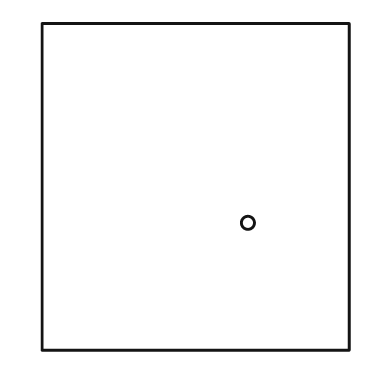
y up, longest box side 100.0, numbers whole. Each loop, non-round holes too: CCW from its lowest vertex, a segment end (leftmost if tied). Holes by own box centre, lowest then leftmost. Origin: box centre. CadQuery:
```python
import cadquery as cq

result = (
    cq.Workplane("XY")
    .moveTo(-47.0, -50.0)
    .lineTo(47.0, -50.0)
    .lineTo(47.0, 50.0)
    .lineTo(-47.0, 50.0)
    .close()
    .moveTo(16.0, -11.0)
    .circle(2.0)
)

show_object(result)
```